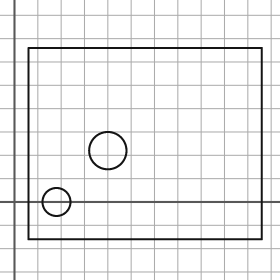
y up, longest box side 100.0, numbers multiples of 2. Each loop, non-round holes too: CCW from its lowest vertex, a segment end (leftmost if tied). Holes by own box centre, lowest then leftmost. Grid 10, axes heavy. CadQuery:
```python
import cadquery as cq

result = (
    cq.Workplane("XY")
    .moveTo(6.0, -16.0)
    .lineTo(106.0, -16.0)
    .lineTo(106.0, 66.0)
    .lineTo(6.0, 66.0)
    .close()
    .moveTo(18.0, 0.0)
    .circle(6.0)
    .moveTo(40.0, 22.0)
    .circle(8.0)
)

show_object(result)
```